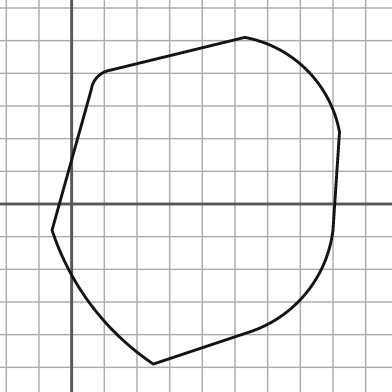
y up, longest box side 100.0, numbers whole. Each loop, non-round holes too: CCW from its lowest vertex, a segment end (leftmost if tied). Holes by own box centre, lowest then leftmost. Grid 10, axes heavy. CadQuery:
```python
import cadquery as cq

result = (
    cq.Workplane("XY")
    .moveTo(25.0, -49.0)
    .lineTo(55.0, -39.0)
    .threePointArc((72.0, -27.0), (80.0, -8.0))
    .lineTo(82.0, 22.0)
    .threePointArc((72.0, 41.0), (53.0, 51.0))
    .lineTo(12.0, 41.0)
    .threePointArc((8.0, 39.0), (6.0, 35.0))
    .lineTo(-6.0, -8.0)
    .threePointArc((6.0, -31.0), (25.0, -49.0))
    .close()
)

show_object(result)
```